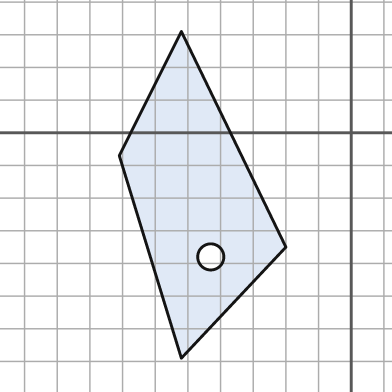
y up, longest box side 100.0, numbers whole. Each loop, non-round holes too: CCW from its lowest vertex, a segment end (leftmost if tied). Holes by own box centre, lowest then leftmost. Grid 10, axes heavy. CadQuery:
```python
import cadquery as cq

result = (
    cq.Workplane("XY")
    .moveTo(-52.0, -69.0)
    .lineTo(-20.0, -35.0)
    .lineTo(-52.0, 31.0)
    .lineTo(-71.0, -7.0)
    .close()
    .moveTo(-43.0, -38.0)
    .circle(4.0)
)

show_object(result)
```